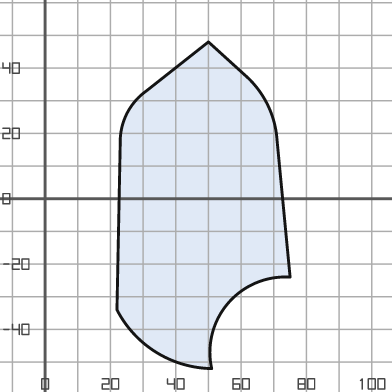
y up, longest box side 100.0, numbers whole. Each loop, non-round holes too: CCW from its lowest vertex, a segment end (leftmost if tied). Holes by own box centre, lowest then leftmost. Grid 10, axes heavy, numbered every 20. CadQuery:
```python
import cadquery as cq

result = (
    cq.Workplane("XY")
    .moveTo(51.0, -52.0)
    .threePointArc((56.0, -32.0), (75.0, -24.0))
    .lineTo(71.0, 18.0)
    .threePointArc((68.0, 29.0), (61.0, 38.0))
    .lineTo(50.0, 48.0)
    .lineTo(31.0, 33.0)
    .threePointArc((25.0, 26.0), (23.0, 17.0))
    .lineTo(22.0, -34.0)
    .threePointArc((34.0, -47.0), (51.0, -52.0))
    .close()
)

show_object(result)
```